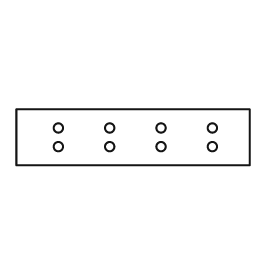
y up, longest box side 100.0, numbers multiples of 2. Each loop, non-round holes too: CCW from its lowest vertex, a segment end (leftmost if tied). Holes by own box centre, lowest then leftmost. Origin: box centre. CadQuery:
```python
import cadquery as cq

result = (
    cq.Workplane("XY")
    .moveTo(-50.0, -12.0)
    .lineTo(50.0, -12.0)
    .lineTo(50.0, 12.0)
    .lineTo(-50.0, 12.0)
    .close()
    .moveTo(-32.0, -4.0)
    .circle(2.0)
    .moveTo(-10.0, -4.0)
    .circle(2.0)
    .moveTo(12.0, -4.0)
    .circle(2.0)
    .moveTo(34.0, -4.0)
    .circle(2.0)
    .moveTo(-32.0, 4.0)
    .circle(2.0)
    .moveTo(-10.0, 4.0)
    .circle(2.0)
    .moveTo(12.0, 4.0)
    .circle(2.0)
    .moveTo(34.0, 4.0)
    .circle(2.0)
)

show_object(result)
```